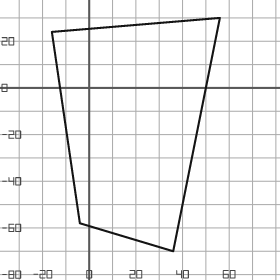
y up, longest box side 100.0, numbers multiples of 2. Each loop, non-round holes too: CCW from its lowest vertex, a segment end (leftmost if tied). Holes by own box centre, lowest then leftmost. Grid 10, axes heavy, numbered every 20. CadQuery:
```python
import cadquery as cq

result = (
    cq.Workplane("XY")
    .moveTo(36.0, -70.0)
    .lineTo(56.0, 30.0)
    .lineTo(-16.0, 24.0)
    .lineTo(-4.0, -58.0)
    .close()
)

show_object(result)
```